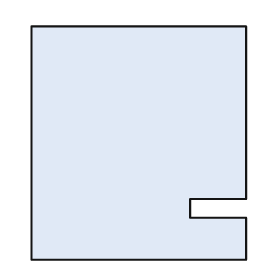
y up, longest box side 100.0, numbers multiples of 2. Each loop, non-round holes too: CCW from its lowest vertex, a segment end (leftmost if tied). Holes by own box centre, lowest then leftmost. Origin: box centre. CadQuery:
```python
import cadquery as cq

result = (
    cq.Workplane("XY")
    .moveTo(-46.0, -50.0)
    .lineTo(46.0, -50.0)
    .lineTo(46.0, -32.0)
    .lineTo(22.0, -32.0)
    .lineTo(22.0, -24.0)
    .lineTo(46.0, -24.0)
    .lineTo(46.0, 50.0)
    .lineTo(-46.0, 50.0)
    .close()
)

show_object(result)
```